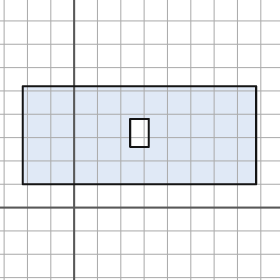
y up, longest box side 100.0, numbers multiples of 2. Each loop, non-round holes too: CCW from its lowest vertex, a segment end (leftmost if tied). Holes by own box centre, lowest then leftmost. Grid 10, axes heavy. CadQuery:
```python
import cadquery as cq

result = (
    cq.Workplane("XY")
    .moveTo(-22.0, 10.0)
    .lineTo(78.0, 10.0)
    .lineTo(78.0, 52.0)
    .lineTo(-22.0, 52.0)
    .close()
    .moveTo(24.0, 26.0)
    .lineTo(32.0, 26.0)
    .lineTo(32.0, 38.0)
    .lineTo(24.0, 38.0)
    .close()
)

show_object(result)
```